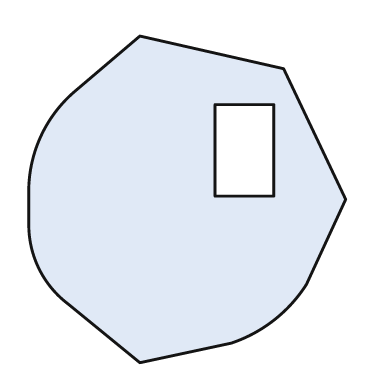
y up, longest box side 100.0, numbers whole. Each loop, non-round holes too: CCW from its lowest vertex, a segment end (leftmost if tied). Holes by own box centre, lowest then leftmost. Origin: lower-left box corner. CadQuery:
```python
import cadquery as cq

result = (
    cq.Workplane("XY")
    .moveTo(34.0, 0.0)
    .lineTo(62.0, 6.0)
    .threePointArc((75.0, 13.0), (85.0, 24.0))
    .lineTo(97.0, 50.0)
    .lineTo(78.0, 90.0)
    .lineTo(34.0, 100.0)
    .lineTo(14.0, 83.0)
    .threePointArc((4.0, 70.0), (0.0, 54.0))
    .lineTo(0.0, 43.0)
    .threePointArc((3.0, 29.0), (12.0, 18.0))
    .close()
    .moveTo(57.0, 51.0)
    .lineTo(75.0, 51.0)
    .lineTo(75.0, 79.0)
    .lineTo(57.0, 79.0)
    .close()
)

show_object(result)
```